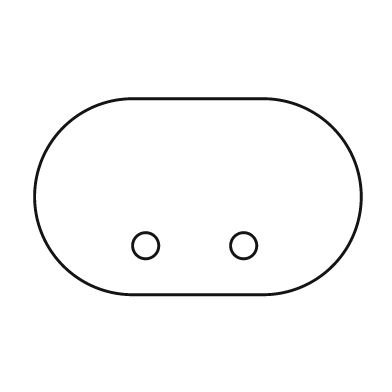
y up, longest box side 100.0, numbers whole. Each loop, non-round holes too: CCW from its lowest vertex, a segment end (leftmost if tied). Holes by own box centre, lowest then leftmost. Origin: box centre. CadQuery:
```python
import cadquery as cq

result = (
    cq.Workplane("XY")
    .moveTo(-20.0, -30.0)
    .lineTo(20.0, -30.0)
    .threePointArc((50.0, 0.0), (20.0, 30.0))
    .lineTo(-20.0, 30.0)
    .threePointArc((-50.0, 0.0), (-20.0, -30.0))
    .close()
    .moveTo(-16.0, -15.0)
    .circle(4.0)
    .moveTo(14.0, -15.0)
    .circle(4.0)
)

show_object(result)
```